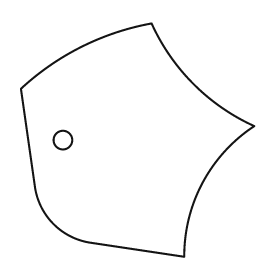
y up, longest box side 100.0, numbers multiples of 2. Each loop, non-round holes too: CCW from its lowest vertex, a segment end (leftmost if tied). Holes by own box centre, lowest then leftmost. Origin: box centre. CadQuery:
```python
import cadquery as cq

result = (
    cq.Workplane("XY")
    .moveTo(20.0, -50.0)
    .threePointArc((28.0, -18.0), (50.0, 6.0))
    .threePointArc((24.0, 24.0), (6.0, 50.0))
    .threePointArc((-24.0, 40.0), (-50.0, 22.0))
    .lineTo(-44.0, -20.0)
    .threePointArc((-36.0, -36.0), (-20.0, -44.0))
    .close()
    .moveTo(-32.0, 0.0)
    .circle(4.0)
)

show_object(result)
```